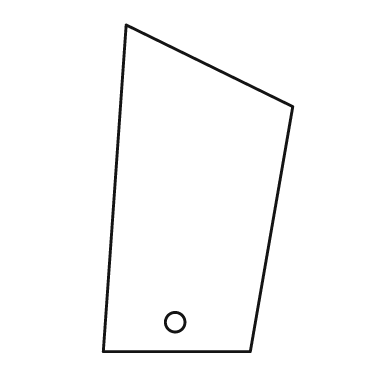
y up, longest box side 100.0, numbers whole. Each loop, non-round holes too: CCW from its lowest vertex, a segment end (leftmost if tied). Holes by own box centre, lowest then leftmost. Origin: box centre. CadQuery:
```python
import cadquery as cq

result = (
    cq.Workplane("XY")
    .moveTo(-29.0, -50.0)
    .lineTo(16.0, -50.0)
    .lineTo(29.0, 25.0)
    .lineTo(-22.0, 50.0)
    .close()
    .moveTo(-7.0, -41.0)
    .circle(3.0)
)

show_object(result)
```